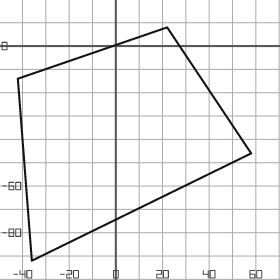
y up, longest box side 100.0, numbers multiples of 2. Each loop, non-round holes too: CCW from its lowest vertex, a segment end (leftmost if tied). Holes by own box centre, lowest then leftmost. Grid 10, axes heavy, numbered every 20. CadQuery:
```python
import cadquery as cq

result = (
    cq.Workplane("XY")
    .moveTo(-36.0, -92.0)
    .lineTo(58.0, -46.0)
    .lineTo(22.0, 8.0)
    .lineTo(-42.0, -14.0)
    .close()
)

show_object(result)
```